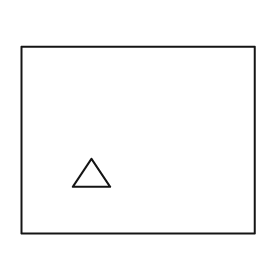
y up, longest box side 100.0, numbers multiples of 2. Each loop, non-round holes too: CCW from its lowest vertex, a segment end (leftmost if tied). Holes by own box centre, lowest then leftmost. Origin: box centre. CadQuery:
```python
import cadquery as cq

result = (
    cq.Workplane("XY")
    .moveTo(-50.0, -40.0)
    .lineTo(50.0, -40.0)
    .lineTo(50.0, 40.0)
    .lineTo(-50.0, 40.0)
    .close()
    .moveTo(-28.0, -20.0)
    .lineTo(-12.0, -20.0)
    .lineTo(-20.0, -8.0)
    .close()
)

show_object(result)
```